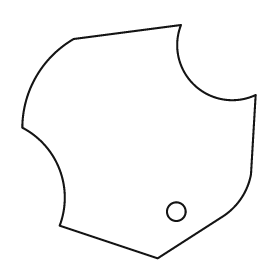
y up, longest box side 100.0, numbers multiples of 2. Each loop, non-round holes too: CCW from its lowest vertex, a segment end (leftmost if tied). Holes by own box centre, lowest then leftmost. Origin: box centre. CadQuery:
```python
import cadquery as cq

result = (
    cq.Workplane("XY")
    .moveTo(8.0, -50.0)
    .lineTo(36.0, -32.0)
    .threePointArc((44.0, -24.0), (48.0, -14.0))
    .lineTo(50.0, 20.0)
    .threePointArc((24.0, 24.0), (18.0, 50.0))
    .lineTo(-28.0, 44.0)
    .threePointArc((-44.0, 28.0), (-50.0, 6.0))
    .threePointArc((-34.0, -12.0), (-34.0, -36.0))
    .close()
    .moveTo(16.0, -30.0)
    .circle(4.0)
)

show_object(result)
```